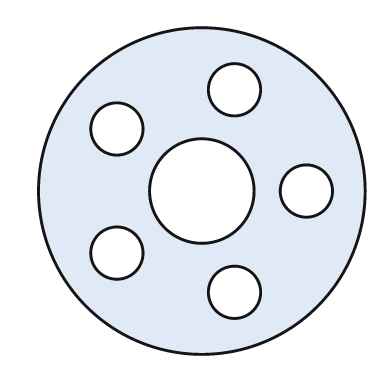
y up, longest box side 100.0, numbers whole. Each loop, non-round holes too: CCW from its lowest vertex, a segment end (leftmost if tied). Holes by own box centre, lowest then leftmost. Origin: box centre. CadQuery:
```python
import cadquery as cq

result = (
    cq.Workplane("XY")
    .moveTo(0.0, 0.0)
    .circle(50.0)
    .moveTo(10.0, -31.0)
    .circle(8.0)
    .moveTo(-26.0, -19.0)
    .circle(8.0)
    .moveTo(0.0, 0.0)
    .circle(16.0)
    .moveTo(32.0, 0.0)
    .circle(8.0)
    .moveTo(-26.0, 19.0)
    .circle(8.0)
    .moveTo(10.0, 31.0)
    .circle(8.0)
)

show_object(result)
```